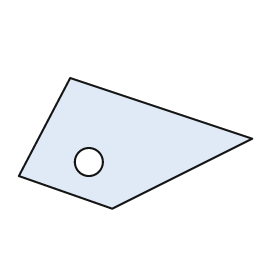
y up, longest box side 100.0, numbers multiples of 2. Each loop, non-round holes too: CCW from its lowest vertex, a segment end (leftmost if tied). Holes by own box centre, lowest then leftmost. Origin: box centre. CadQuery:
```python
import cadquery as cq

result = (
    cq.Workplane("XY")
    .moveTo(-10.0, -28.0)
    .lineTo(50.0, 2.0)
    .lineTo(-28.0, 28.0)
    .lineTo(-50.0, -14.0)
    .close()
    .moveTo(-20.0, -8.0)
    .circle(6.0)
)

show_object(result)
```